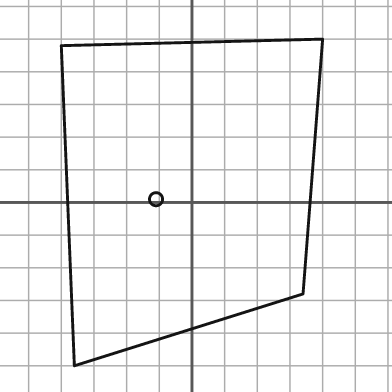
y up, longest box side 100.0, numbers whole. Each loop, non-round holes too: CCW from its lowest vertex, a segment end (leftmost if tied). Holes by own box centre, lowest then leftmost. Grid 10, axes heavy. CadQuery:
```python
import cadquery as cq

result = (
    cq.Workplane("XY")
    .moveTo(-36.0, -50.0)
    .lineTo(34.0, -28.0)
    .lineTo(40.0, 50.0)
    .lineTo(-40.0, 48.0)
    .close()
    .moveTo(-11.0, 1.0)
    .circle(2.0)
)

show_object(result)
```